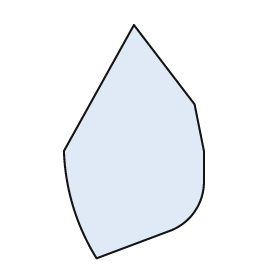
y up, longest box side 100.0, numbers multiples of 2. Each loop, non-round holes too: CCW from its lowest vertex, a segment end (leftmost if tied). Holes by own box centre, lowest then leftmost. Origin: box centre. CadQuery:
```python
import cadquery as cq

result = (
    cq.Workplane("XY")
    .moveTo(-16.0, -50.0)
    .lineTo(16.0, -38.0)
    .threePointArc((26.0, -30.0), (30.0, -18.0))
    .lineTo(30.0, -4.0)
    .lineTo(26.0, 16.0)
    .lineTo(0.0, 50.0)
    .lineTo(-30.0, -4.0)
    .threePointArc((-26.0, -28.0), (-16.0, -50.0))
    .close()
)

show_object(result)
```